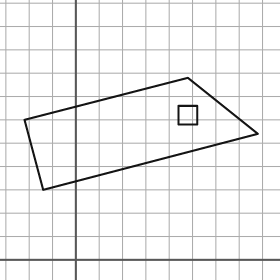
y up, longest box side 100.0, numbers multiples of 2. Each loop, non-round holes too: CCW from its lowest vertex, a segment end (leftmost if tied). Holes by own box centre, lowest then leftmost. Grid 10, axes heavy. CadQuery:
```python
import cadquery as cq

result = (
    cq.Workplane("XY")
    .moveTo(-14.0, 30.0)
    .lineTo(78.0, 54.0)
    .lineTo(48.0, 78.0)
    .lineTo(-22.0, 60.0)
    .close()
    .moveTo(44.0, 58.0)
    .lineTo(52.0, 58.0)
    .lineTo(52.0, 66.0)
    .lineTo(44.0, 66.0)
    .close()
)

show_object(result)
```